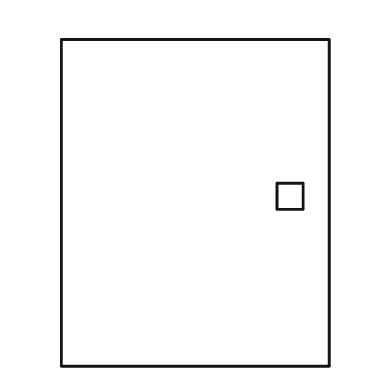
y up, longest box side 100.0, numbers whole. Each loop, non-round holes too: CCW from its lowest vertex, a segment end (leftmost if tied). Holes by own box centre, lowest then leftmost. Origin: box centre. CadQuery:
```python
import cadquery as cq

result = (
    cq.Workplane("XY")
    .moveTo(-41.0, -50.0)
    .lineTo(41.0, -50.0)
    .lineTo(41.0, 50.0)
    .lineTo(-41.0, 50.0)
    .close()
    .moveTo(25.0, -2.0)
    .lineTo(33.0, -2.0)
    .lineTo(33.0, 6.0)
    .lineTo(25.0, 6.0)
    .close()
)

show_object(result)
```